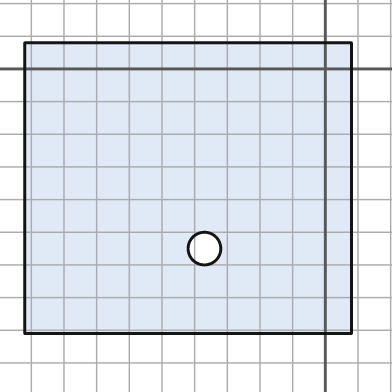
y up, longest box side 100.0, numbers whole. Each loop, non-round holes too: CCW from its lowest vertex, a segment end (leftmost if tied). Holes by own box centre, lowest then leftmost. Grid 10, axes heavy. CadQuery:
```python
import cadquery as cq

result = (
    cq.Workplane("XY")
    .moveTo(-92.0, -81.0)
    .lineTo(8.0, -81.0)
    .lineTo(8.0, 8.0)
    .lineTo(-92.0, 8.0)
    .close()
    .moveTo(-37.0, -55.0)
    .circle(5.0)
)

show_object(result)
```